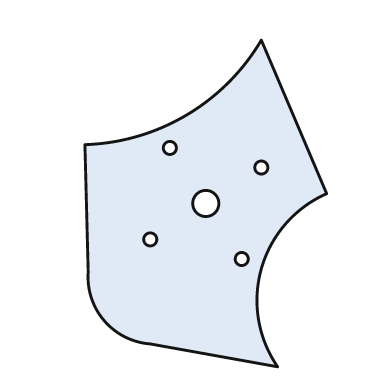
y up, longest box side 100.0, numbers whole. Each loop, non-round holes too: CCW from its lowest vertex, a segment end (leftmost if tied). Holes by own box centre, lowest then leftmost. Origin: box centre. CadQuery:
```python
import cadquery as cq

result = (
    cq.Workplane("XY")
    .moveTo(22.0, -50.0)
    .threePointArc((17.0, -20.0), (37.0, 3.0))
    .lineTo(17.0, 50.0)
    .threePointArc((-6.0, 27.0), (-37.0, 18.0))
    .lineTo(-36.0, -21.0)
    .threePointArc((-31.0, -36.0), (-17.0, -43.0))
    .close()
    .moveTo(11.0, -17.0)
    .circle(2.0)
    .moveTo(-17.0, -11.0)
    .circle(2.0)
    .moveTo(0.0, 0.0)
    .circle(4.0)
    .moveTo(17.0, 11.0)
    .circle(2.0)
    .moveTo(-11.0, 17.0)
    .circle(2.0)
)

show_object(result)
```